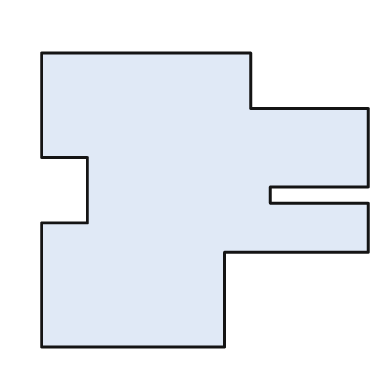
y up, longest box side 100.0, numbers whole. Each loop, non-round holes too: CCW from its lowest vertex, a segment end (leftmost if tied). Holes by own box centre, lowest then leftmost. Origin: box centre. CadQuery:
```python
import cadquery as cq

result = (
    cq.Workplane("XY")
    .moveTo(-50.0, -45.0)
    .lineTo(6.0, -45.0)
    .lineTo(6.0, -16.0)
    .lineTo(50.0, -16.0)
    .lineTo(50.0, -1.0)
    .lineTo(20.0, -1.0)
    .lineTo(20.0, 4.0)
    .lineTo(50.0, 4.0)
    .lineTo(50.0, 28.0)
    .lineTo(14.0, 28.0)
    .lineTo(14.0, 45.0)
    .lineTo(-50.0, 45.0)
    .lineTo(-50.0, 13.0)
    .lineTo(-36.0, 13.0)
    .lineTo(-36.0, -7.0)
    .lineTo(-50.0, -7.0)
    .close()
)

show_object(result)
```